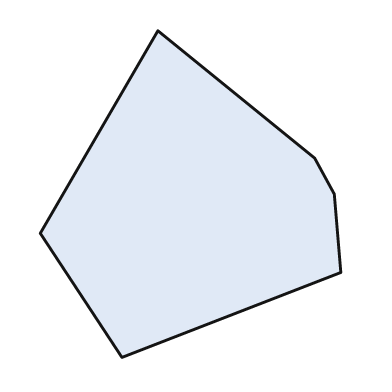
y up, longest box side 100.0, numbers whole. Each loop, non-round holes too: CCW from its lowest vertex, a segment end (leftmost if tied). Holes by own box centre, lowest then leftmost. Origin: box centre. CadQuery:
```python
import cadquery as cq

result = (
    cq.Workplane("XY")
    .moveTo(-21.0, -50.0)
    .lineTo(46.0, -24.0)
    .lineTo(44.0, 0.0)
    .lineTo(38.0, 11.0)
    .lineTo(-10.0, 50.0)
    .lineTo(-46.0, -12.0)
    .close()
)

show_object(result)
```